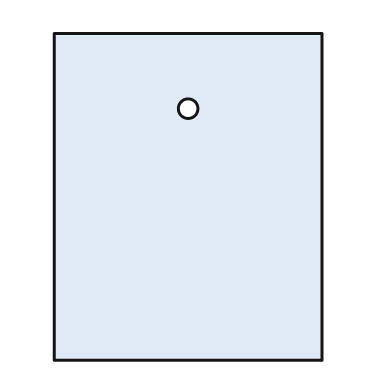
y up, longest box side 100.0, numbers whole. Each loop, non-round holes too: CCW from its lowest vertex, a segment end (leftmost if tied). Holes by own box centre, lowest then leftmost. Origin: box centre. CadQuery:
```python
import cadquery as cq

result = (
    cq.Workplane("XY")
    .moveTo(-41.0, -50.0)
    .lineTo(41.0, -50.0)
    .lineTo(41.0, 50.0)
    .lineTo(-41.0, 50.0)
    .close()
    .moveTo(0.0, 27.0)
    .circle(3.0)
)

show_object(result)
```